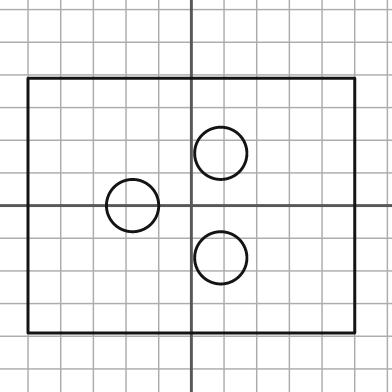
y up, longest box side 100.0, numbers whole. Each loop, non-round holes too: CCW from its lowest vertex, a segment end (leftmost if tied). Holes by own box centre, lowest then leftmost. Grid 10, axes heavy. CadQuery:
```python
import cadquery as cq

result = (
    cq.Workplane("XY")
    .moveTo(-50.0, -39.0)
    .lineTo(50.0, -39.0)
    .lineTo(50.0, 39.0)
    .lineTo(-50.0, 39.0)
    .close()
    .moveTo(9.0, -16.0)
    .circle(8.0)
    .moveTo(-18.0, 0.0)
    .circle(8.0)
    .moveTo(9.0, 16.0)
    .circle(8.0)
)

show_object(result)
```